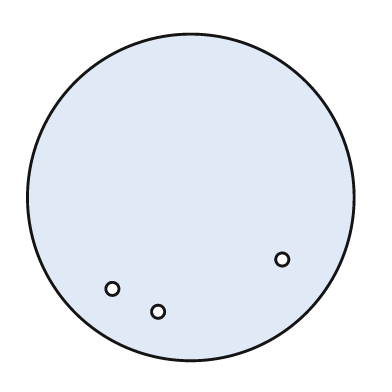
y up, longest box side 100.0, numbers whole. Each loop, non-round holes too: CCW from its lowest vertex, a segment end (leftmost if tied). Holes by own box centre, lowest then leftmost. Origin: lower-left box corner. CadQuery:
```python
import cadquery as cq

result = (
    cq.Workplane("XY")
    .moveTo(50.0, 50.0)
    .circle(50.0)
    .moveTo(40.0, 15.0)
    .circle(2.0)
    .moveTo(26.0, 22.0)
    .circle(2.0)
    .moveTo(78.0, 31.0)
    .circle(2.0)
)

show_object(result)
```